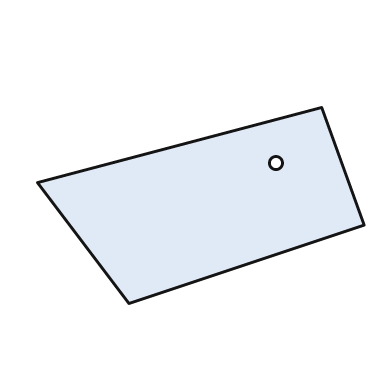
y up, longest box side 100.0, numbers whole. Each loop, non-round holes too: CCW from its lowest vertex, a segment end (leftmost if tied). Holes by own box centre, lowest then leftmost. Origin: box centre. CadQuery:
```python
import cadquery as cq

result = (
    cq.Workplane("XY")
    .moveTo(-22.0, -30.0)
    .lineTo(50.0, -6.0)
    .lineTo(37.0, 30.0)
    .lineTo(-50.0, 7.0)
    .close()
    .moveTo(23.0, 13.0)
    .circle(2.0)
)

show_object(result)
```